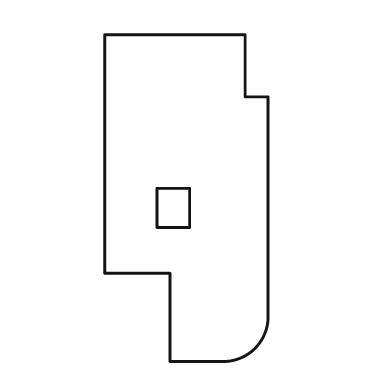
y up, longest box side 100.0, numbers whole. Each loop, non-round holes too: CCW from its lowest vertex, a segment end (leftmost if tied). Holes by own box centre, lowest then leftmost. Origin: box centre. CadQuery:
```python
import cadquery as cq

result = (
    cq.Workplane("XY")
    .moveTo(-5.0, -50.0)
    .lineTo(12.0, -50.0)
    .threePointArc((21.0, -46.0), (25.0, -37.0))
    .lineTo(25.0, 31.0)
    .lineTo(18.0, 31.0)
    .lineTo(18.0, 50.0)
    .lineTo(-25.0, 50.0)
    .lineTo(-25.0, -23.0)
    .lineTo(-5.0, -23.0)
    .close()
    .moveTo(-9.0, -9.0)
    .lineTo(1.0, -9.0)
    .lineTo(1.0, 3.0)
    .lineTo(-9.0, 3.0)
    .close()
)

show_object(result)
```